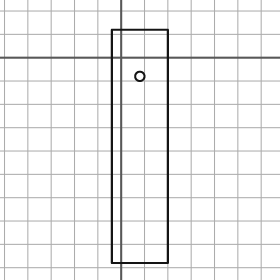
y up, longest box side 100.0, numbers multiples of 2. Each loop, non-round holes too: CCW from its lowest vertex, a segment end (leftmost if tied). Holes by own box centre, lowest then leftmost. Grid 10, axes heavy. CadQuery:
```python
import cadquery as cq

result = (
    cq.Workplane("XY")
    .moveTo(-4.0, -88.0)
    .lineTo(20.0, -88.0)
    .lineTo(20.0, 12.0)
    .lineTo(-4.0, 12.0)
    .close()
    .moveTo(8.0, -8.0)
    .circle(2.0)
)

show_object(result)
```